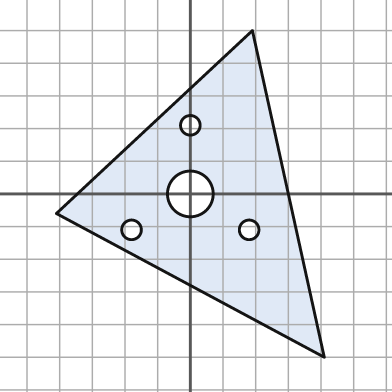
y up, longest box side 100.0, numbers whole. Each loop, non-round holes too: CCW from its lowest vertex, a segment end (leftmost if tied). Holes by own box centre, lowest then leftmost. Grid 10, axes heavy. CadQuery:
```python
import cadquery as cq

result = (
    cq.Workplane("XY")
    .moveTo(41.0, -50.0)
    .lineTo(19.0, 50.0)
    .lineTo(-41.0, -6.0)
    .close()
    .moveTo(-18.0, -11.0)
    .circle(3.0)
    .moveTo(18.0, -11.0)
    .circle(3.0)
    .moveTo(0.0, 0.0)
    .circle(7.0)
    .moveTo(0.0, 21.0)
    .circle(3.0)
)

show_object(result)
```